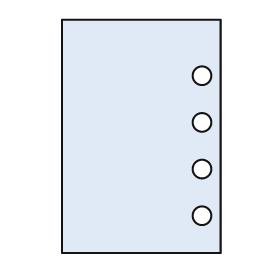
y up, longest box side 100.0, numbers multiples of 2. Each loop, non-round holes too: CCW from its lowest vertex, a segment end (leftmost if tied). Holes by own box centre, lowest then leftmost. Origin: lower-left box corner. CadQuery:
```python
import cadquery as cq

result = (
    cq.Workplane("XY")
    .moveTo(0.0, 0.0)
    .lineTo(68.0, 0.0)
    .lineTo(68.0, 100.0)
    .lineTo(0.0, 100.0)
    .close()
    .moveTo(60.0, 16.0)
    .circle(4.0)
    .moveTo(60.0, 36.0)
    .circle(4.0)
    .moveTo(60.0, 56.0)
    .circle(4.0)
    .moveTo(60.0, 76.0)
    .circle(4.0)
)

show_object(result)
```